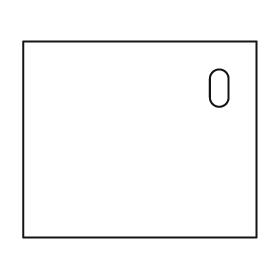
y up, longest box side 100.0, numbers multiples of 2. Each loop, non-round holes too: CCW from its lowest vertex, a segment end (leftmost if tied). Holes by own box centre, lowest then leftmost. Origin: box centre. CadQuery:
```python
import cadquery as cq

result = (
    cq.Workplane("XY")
    .moveTo(-50.0, -42.0)
    .lineTo(50.0, -42.0)
    .lineTo(50.0, 42.0)
    .lineTo(-50.0, 42.0)
    .close()
    .moveTo(30.0, 18.0)
    .threePointArc((34.0, 14.0), (38.0, 18.0))
    .lineTo(38.0, 26.0)
    .threePointArc((34.0, 30.0), (30.0, 26.0))
    .close()
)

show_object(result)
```